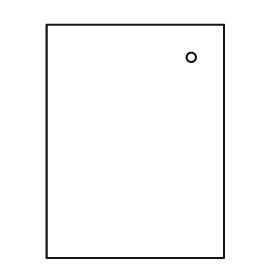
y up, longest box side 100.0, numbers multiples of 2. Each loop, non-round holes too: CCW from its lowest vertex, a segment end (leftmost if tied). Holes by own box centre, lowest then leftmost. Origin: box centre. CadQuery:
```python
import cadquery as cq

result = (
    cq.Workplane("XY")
    .moveTo(-38.0, -50.0)
    .lineTo(38.0, -50.0)
    .lineTo(38.0, 50.0)
    .lineTo(-38.0, 50.0)
    .close()
    .moveTo(24.0, 36.0)
    .circle(2.0)
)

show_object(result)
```